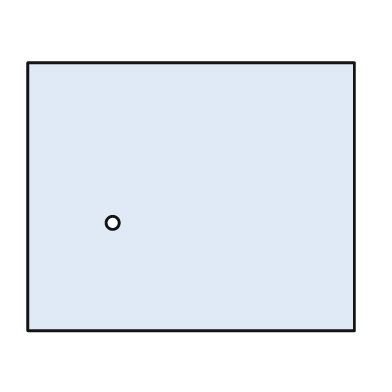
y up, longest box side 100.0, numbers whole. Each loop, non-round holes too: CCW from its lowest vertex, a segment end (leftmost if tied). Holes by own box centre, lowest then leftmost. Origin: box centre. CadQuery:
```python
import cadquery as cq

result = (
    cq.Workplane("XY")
    .moveTo(-50.0, -41.0)
    .lineTo(50.0, -41.0)
    .lineTo(50.0, 41.0)
    .lineTo(-50.0, 41.0)
    .close()
    .moveTo(-24.0, -8.0)
    .circle(2.0)
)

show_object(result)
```